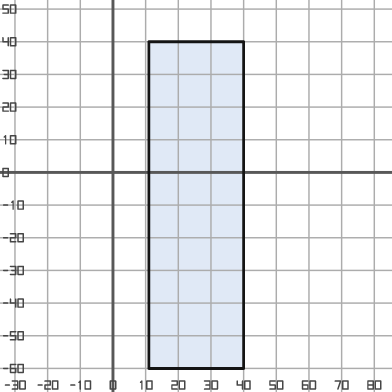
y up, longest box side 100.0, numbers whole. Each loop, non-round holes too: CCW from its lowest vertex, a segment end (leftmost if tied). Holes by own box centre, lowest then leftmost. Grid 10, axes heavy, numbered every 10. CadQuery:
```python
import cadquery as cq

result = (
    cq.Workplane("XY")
    .moveTo(11.0, -60.0)
    .lineTo(40.0, -60.0)
    .lineTo(40.0, 40.0)
    .lineTo(11.0, 40.0)
    .close()
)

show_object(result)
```